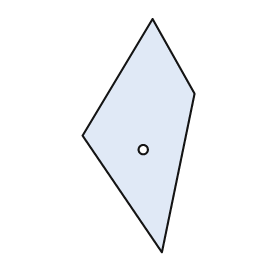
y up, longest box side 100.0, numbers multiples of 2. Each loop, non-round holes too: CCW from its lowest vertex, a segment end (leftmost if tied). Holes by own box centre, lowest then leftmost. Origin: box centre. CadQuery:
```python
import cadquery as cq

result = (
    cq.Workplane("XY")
    .moveTo(10.0, -50.0)
    .lineTo(24.0, 18.0)
    .lineTo(6.0, 50.0)
    .lineTo(-24.0, 0.0)
    .close()
    .moveTo(2.0, -6.0)
    .circle(2.0)
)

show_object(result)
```